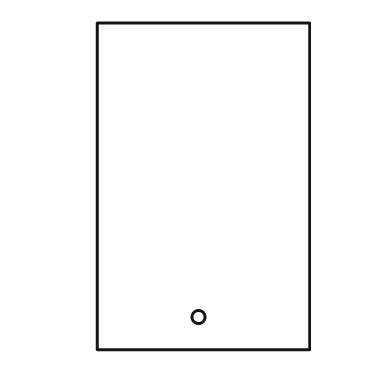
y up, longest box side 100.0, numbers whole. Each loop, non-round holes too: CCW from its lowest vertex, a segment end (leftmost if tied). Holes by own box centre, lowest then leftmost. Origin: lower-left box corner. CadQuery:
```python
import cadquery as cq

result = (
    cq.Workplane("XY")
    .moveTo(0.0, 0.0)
    .lineTo(65.0, 0.0)
    .lineTo(65.0, 100.0)
    .lineTo(0.0, 100.0)
    .close()
    .moveTo(31.0, 10.0)
    .circle(2.0)
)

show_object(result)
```